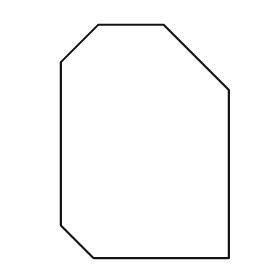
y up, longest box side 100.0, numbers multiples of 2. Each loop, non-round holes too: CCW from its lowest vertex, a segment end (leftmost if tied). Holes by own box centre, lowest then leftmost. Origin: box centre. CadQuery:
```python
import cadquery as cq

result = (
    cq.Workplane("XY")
    .moveTo(-22.0, -50.0)
    .lineTo(36.0, -50.0)
    .lineTo(36.0, 22.0)
    .lineTo(8.0, 50.0)
    .lineTo(-20.0, 50.0)
    .lineTo(-36.0, 34.0)
    .lineTo(-36.0, -36.0)
    .close()
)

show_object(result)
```